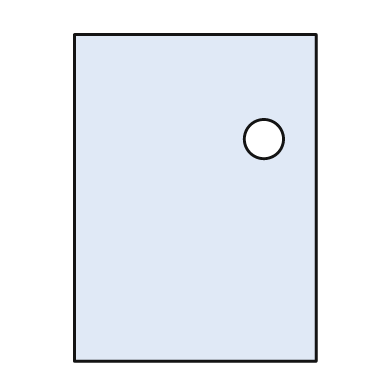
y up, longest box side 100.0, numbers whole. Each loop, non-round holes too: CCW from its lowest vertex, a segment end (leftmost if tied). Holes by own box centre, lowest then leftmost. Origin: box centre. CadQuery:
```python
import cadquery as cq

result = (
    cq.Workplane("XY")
    .moveTo(-37.0, -50.0)
    .lineTo(37.0, -50.0)
    .lineTo(37.0, 50.0)
    .lineTo(-37.0, 50.0)
    .close()
    .moveTo(21.0, 18.0)
    .circle(6.0)
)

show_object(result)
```